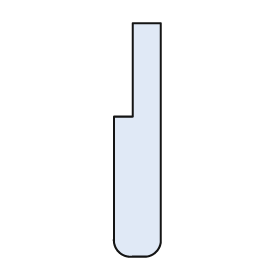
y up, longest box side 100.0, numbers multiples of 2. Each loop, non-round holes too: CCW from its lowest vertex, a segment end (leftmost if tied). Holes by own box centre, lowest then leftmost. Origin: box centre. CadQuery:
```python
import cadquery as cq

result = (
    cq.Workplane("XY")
    .moveTo(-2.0, -50.0)
    .lineTo(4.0, -50.0)
    .threePointArc((8.0, -48.0), (10.0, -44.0))
    .lineTo(10.0, 50.0)
    .lineTo(-2.0, 50.0)
    .lineTo(-2.0, 10.0)
    .lineTo(-10.0, 10.0)
    .lineTo(-10.0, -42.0)
    .threePointArc((-8.0, -48.0), (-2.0, -50.0))
    .close()
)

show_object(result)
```